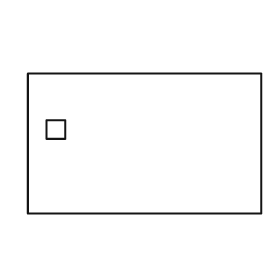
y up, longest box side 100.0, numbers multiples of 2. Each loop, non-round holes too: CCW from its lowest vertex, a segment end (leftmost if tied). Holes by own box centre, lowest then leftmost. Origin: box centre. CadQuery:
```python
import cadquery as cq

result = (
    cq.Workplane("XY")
    .moveTo(-50.0, -30.0)
    .lineTo(50.0, -30.0)
    .lineTo(50.0, 30.0)
    .lineTo(-50.0, 30.0)
    .close()
    .moveTo(-42.0, 2.0)
    .lineTo(-34.0, 2.0)
    .lineTo(-34.0, 10.0)
    .lineTo(-42.0, 10.0)
    .close()
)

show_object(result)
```